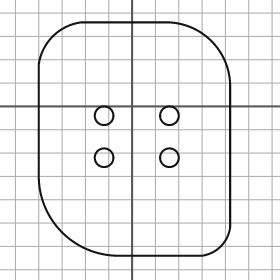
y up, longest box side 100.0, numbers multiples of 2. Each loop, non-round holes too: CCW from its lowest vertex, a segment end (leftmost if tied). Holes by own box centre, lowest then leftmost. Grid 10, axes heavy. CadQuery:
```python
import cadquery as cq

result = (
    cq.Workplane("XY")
    .moveTo(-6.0, -64.0)
    .lineTo(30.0, -64.0)
    .threePointArc((38.0, -60.0), (42.0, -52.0))
    .lineTo(42.0, 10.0)
    .threePointArc((34.0, 28.0), (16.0, 36.0))
    .lineTo(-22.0, 36.0)
    .threePointArc((-34.0, 30.0), (-40.0, 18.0))
    .lineTo(-40.0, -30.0)
    .threePointArc((-30.0, -54.0), (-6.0, -64.0))
    .close()
    .moveTo(-12.0, -22.0)
    .circle(4.0)
    .moveTo(16.0, -22.0)
    .circle(4.0)
    .moveTo(-12.0, -4.0)
    .circle(4.0)
    .moveTo(16.0, -4.0)
    .circle(4.0)
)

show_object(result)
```